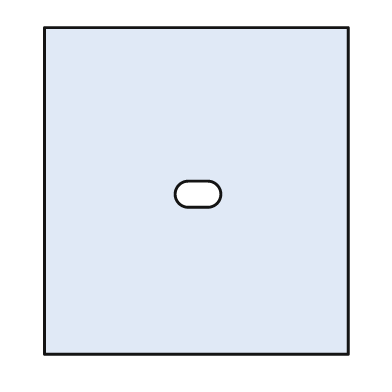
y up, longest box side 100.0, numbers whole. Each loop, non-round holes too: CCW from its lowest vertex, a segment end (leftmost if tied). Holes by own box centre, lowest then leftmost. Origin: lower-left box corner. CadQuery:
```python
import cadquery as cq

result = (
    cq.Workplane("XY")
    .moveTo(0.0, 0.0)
    .lineTo(93.0, 0.0)
    .lineTo(93.0, 100.0)
    .lineTo(0.0, 100.0)
    .close()
    .moveTo(44.0, 45.0)
    .lineTo(50.0, 45.0)
    .threePointArc((54.0, 49.0), (50.0, 53.0))
    .lineTo(44.0, 53.0)
    .threePointArc((40.0, 49.0), (44.0, 45.0))
    .close()
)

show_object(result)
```